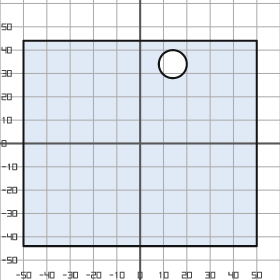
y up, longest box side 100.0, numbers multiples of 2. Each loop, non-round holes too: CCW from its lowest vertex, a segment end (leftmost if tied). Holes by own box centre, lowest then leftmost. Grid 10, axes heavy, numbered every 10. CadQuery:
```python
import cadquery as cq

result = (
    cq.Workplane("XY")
    .moveTo(-50.0, -44.0)
    .lineTo(50.0, -44.0)
    .lineTo(50.0, 44.0)
    .lineTo(-50.0, 44.0)
    .close()
    .moveTo(14.0, 34.0)
    .circle(6.0)
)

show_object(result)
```